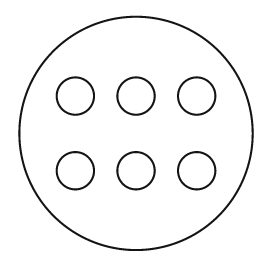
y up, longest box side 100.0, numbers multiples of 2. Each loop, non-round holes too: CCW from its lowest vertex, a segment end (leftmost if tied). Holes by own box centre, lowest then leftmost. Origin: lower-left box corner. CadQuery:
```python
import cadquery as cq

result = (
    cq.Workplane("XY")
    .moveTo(50.0, 50.0)
    .circle(50.0)
    .moveTo(24.0, 34.0)
    .circle(8.0)
    .moveTo(50.0, 34.0)
    .circle(8.0)
    .moveTo(76.0, 34.0)
    .circle(8.0)
    .moveTo(24.0, 66.0)
    .circle(8.0)
    .moveTo(50.0, 66.0)
    .circle(8.0)
    .moveTo(76.0, 66.0)
    .circle(8.0)
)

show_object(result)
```